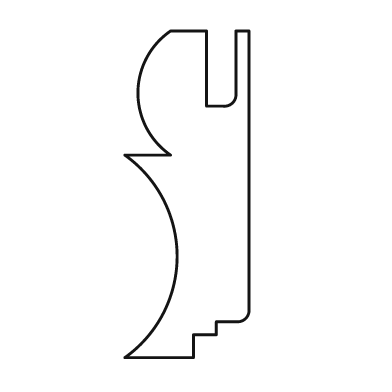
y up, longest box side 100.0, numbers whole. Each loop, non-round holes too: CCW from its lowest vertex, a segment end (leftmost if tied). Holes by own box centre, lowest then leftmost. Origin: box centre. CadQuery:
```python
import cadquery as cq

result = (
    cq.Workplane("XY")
    .moveTo(-19.0, -50.0)
    .lineTo(2.0, -50.0)
    .lineTo(2.0, -43.0)
    .lineTo(9.0, -43.0)
    .lineTo(9.0, -39.0)
    .lineTo(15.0, -39.0)
    .threePointArc((18.0, -38.0), (19.0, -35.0))
    .lineTo(19.0, 50.0)
    .lineTo(15.0, 50.0)
    .lineTo(15.0, 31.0)
    .threePointArc((14.0, 28.0), (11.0, 27.0))
    .lineTo(6.0, 27.0)
    .lineTo(6.0, 50.0)
    .lineTo(-5.0, 50.0)
    .threePointArc((-15.0, 31.0), (-5.0, 12.0))
    .lineTo(-19.0, 12.0)
    .threePointArc((-3.0, -19.0), (-19.0, -50.0))
    .close()
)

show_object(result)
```